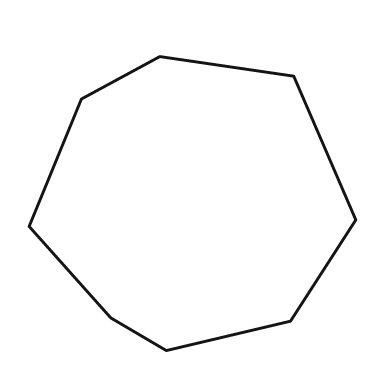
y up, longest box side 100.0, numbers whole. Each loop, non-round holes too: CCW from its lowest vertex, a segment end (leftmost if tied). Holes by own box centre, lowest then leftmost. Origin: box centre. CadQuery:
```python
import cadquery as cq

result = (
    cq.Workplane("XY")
    .moveTo(-8.0, -45.0)
    .lineTo(30.0, -36.0)
    .lineTo(50.0, -5.0)
    .lineTo(31.0, 39.0)
    .lineTo(-10.0, 45.0)
    .lineTo(-34.0, 32.0)
    .lineTo(-50.0, -7.0)
    .lineTo(-25.0, -35.0)
    .close()
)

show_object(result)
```